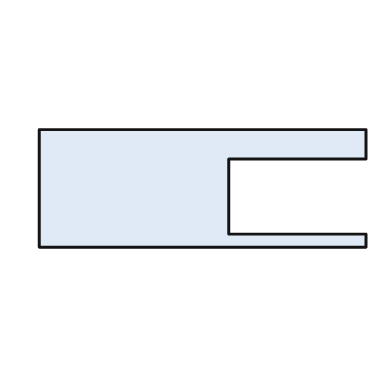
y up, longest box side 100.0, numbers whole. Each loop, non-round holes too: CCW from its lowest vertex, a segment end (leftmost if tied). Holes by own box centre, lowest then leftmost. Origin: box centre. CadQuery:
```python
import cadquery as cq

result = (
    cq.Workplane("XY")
    .moveTo(-50.0, -18.0)
    .lineTo(50.0, -18.0)
    .lineTo(50.0, -14.0)
    .lineTo(8.0, -14.0)
    .lineTo(8.0, 9.0)
    .lineTo(50.0, 9.0)
    .lineTo(50.0, 18.0)
    .lineTo(-50.0, 18.0)
    .close()
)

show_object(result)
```